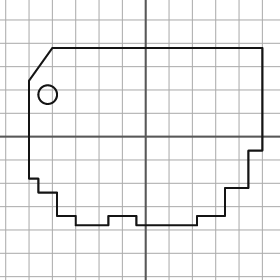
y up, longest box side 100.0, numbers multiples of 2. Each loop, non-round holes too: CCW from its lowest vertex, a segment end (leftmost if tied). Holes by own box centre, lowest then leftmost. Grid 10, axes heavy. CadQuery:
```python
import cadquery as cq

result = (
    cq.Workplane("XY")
    .moveTo(-30.0, -38.0)
    .lineTo(-16.0, -38.0)
    .lineTo(-16.0, -34.0)
    .lineTo(-4.0, -34.0)
    .lineTo(-4.0, -38.0)
    .lineTo(22.0, -38.0)
    .lineTo(22.0, -34.0)
    .lineTo(34.0, -34.0)
    .lineTo(34.0, -22.0)
    .lineTo(44.0, -22.0)
    .lineTo(44.0, -6.0)
    .lineTo(50.0, -6.0)
    .lineTo(50.0, 38.0)
    .lineTo(-40.0, 38.0)
    .lineTo(-50.0, 24.0)
    .lineTo(-50.0, -18.0)
    .lineTo(-46.0, -18.0)
    .lineTo(-46.0, -24.0)
    .lineTo(-38.0, -24.0)
    .lineTo(-38.0, -34.0)
    .lineTo(-30.0, -34.0)
    .close()
    .moveTo(-42.0, 18.0)
    .circle(4.0)
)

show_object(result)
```